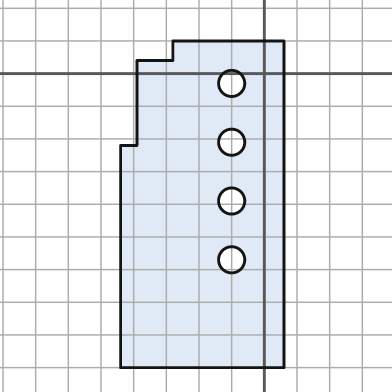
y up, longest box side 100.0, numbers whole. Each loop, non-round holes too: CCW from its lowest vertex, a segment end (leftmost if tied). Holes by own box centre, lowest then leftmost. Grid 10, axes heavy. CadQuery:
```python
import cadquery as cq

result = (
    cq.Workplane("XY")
    .moveTo(-44.0, -90.0)
    .lineTo(6.0, -90.0)
    .lineTo(6.0, 10.0)
    .lineTo(-28.0, 10.0)
    .lineTo(-28.0, 4.0)
    .lineTo(-39.0, 4.0)
    .lineTo(-39.0, -22.0)
    .lineTo(-44.0, -22.0)
    .close()
    .moveTo(-10.0, -57.0)
    .circle(4.0)
    .moveTo(-10.0, -39.0)
    .circle(4.0)
    .moveTo(-10.0, -21.0)
    .circle(4.0)
    .moveTo(-10.0, -3.0)
    .circle(4.0)
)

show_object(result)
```